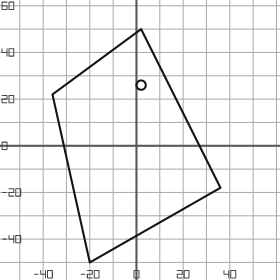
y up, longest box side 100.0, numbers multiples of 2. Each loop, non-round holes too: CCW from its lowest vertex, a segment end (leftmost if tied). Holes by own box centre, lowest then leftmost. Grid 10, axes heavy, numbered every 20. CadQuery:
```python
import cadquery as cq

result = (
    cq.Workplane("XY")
    .moveTo(-20.0, -50.0)
    .lineTo(36.0, -18.0)
    .lineTo(2.0, 50.0)
    .lineTo(-36.0, 22.0)
    .close()
    .moveTo(2.0, 26.0)
    .circle(2.0)
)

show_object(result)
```